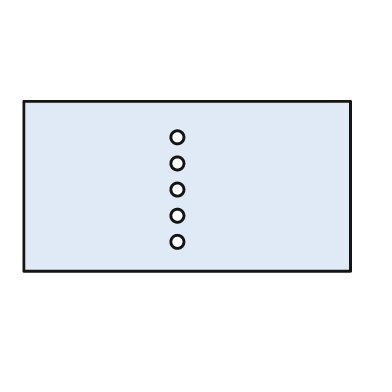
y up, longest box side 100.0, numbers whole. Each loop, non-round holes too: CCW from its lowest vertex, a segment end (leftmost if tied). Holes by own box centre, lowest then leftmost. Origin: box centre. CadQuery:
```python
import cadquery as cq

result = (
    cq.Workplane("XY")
    .moveTo(-50.0, -26.0)
    .lineTo(50.0, -26.0)
    .lineTo(50.0, 26.0)
    .lineTo(-50.0, 26.0)
    .close()
    .moveTo(-3.0, -17.0)
    .circle(2.0)
    .moveTo(-3.0, -9.0)
    .circle(2.0)
    .moveTo(-3.0, -1.0)
    .circle(2.0)
    .moveTo(-3.0, 7.0)
    .circle(2.0)
    .moveTo(-3.0, 15.0)
    .circle(2.0)
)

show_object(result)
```